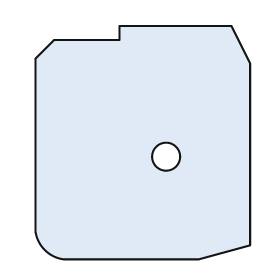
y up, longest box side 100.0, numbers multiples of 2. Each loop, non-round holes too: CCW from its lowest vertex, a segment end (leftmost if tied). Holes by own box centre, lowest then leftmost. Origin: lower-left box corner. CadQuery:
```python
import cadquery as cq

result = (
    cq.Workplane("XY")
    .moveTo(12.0, 0.0)
    .lineTo(70.0, 0.0)
    .lineTo(92.0, 6.0)
    .lineTo(92.0, 84.0)
    .lineTo(84.0, 100.0)
    .lineTo(36.0, 100.0)
    .lineTo(36.0, 94.0)
    .lineTo(8.0, 94.0)
    .lineTo(0.0, 86.0)
    .lineTo(0.0, 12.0)
    .threePointArc((4.0, 4.0), (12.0, 0.0))
    .close()
    .moveTo(56.0, 44.0)
    .circle(6.0)
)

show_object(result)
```